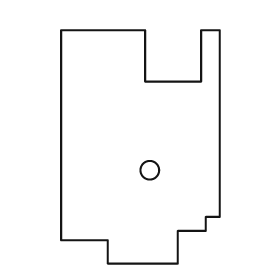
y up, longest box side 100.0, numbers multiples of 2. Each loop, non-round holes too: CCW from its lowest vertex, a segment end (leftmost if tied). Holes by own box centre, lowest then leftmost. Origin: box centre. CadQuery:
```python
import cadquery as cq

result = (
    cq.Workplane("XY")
    .moveTo(-14.0, -50.0)
    .lineTo(16.0, -50.0)
    .lineTo(16.0, -36.0)
    .lineTo(28.0, -36.0)
    .lineTo(28.0, -30.0)
    .lineTo(34.0, -30.0)
    .lineTo(34.0, 50.0)
    .lineTo(26.0, 50.0)
    .lineTo(26.0, 28.0)
    .lineTo(2.0, 28.0)
    .lineTo(2.0, 50.0)
    .lineTo(-34.0, 50.0)
    .lineTo(-34.0, -40.0)
    .lineTo(-14.0, -40.0)
    .close()
    .moveTo(4.0, -10.0)
    .circle(4.0)
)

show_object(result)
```